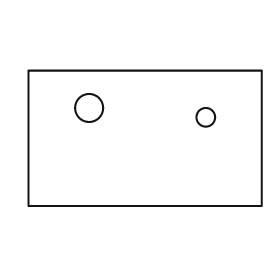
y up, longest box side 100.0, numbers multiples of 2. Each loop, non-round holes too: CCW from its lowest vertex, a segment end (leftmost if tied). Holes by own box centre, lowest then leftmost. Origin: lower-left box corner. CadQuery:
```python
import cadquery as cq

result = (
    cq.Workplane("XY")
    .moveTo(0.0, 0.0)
    .lineTo(100.0, 0.0)
    .lineTo(100.0, 58.0)
    .lineTo(0.0, 58.0)
    .close()
    .moveTo(76.0, 38.0)
    .circle(4.0)
    .moveTo(26.0, 42.0)
    .circle(6.0)
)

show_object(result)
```